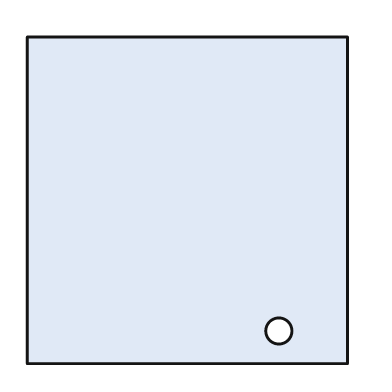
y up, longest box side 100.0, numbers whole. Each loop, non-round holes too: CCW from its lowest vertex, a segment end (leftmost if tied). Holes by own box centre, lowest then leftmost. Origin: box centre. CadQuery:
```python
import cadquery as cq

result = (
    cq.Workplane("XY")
    .moveTo(-49.0, -50.0)
    .lineTo(49.0, -50.0)
    .lineTo(49.0, 50.0)
    .lineTo(-49.0, 50.0)
    .close()
    .moveTo(28.0, -40.0)
    .circle(4.0)
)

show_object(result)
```